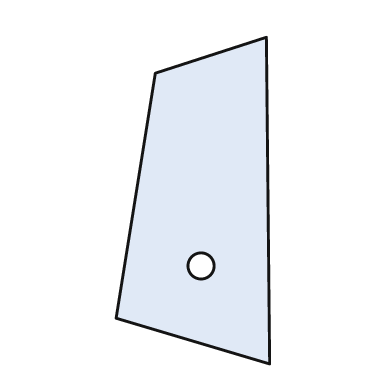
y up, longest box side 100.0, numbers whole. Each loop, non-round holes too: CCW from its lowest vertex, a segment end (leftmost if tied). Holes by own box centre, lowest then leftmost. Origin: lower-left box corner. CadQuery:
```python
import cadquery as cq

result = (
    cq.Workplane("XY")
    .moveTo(47.0, 0.0)
    .lineTo(46.0, 100.0)
    .lineTo(12.0, 89.0)
    .lineTo(0.0, 14.0)
    .close()
    .moveTo(26.0, 30.0)
    .circle(4.0)
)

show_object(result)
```